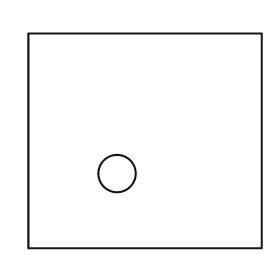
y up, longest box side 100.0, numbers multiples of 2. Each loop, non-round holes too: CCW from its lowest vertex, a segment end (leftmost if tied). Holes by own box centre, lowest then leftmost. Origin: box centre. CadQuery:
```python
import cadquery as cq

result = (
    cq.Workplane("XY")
    .moveTo(-50.0, -46.0)
    .lineTo(50.0, -46.0)
    .lineTo(50.0, 46.0)
    .lineTo(-50.0, 46.0)
    .close()
    .moveTo(-12.0, -14.0)
    .circle(8.0)
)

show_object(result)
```